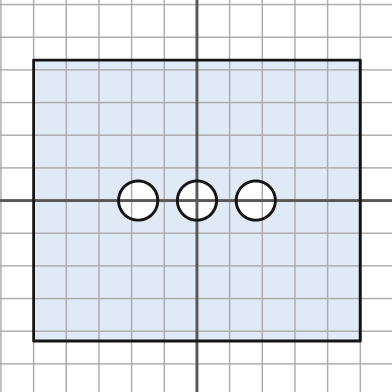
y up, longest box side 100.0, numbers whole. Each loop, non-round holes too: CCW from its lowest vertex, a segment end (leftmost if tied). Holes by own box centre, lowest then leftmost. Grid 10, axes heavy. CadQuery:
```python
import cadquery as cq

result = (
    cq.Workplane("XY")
    .moveTo(-50.0, -43.0)
    .lineTo(50.0, -43.0)
    .lineTo(50.0, 43.0)
    .lineTo(-50.0, 43.0)
    .close()
    .moveTo(-18.0, 0.0)
    .circle(6.0)
    .moveTo(0.0, 0.0)
    .circle(6.0)
    .moveTo(18.0, 0.0)
    .circle(6.0)
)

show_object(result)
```